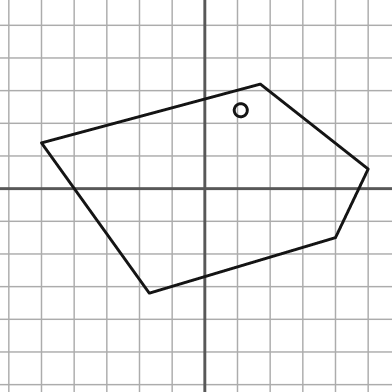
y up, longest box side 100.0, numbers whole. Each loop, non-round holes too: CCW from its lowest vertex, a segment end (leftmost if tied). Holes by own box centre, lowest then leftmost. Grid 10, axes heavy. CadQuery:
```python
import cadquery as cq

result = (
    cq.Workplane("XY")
    .moveTo(-17.0, -32.0)
    .lineTo(40.0, -15.0)
    .lineTo(50.0, 6.0)
    .lineTo(17.0, 32.0)
    .lineTo(-50.0, 14.0)
    .close()
    .moveTo(11.0, 24.0)
    .circle(2.0)
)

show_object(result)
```